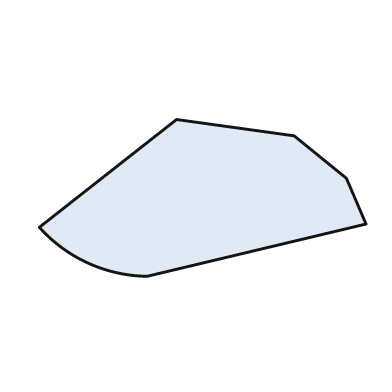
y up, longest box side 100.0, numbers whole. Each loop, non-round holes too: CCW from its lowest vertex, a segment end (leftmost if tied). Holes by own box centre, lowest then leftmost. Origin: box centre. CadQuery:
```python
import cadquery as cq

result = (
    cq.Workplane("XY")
    .moveTo(-17.0, -24.0)
    .lineTo(50.0, -8.0)
    .lineTo(44.0, 6.0)
    .lineTo(28.0, 19.0)
    .lineTo(-8.0, 24.0)
    .lineTo(-50.0, -9.0)
    .threePointArc((-35.0, -20.0), (-17.0, -24.0))
    .close()
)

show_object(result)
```